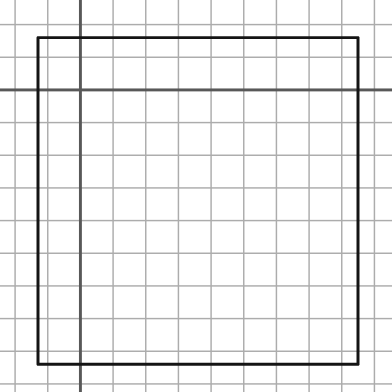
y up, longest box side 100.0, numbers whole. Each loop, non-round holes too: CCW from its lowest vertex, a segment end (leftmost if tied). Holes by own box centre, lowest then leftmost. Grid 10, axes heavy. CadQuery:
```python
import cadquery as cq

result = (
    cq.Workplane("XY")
    .moveTo(-13.0, -84.0)
    .lineTo(85.0, -84.0)
    .lineTo(85.0, 16.0)
    .lineTo(-13.0, 16.0)
    .close()
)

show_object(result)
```